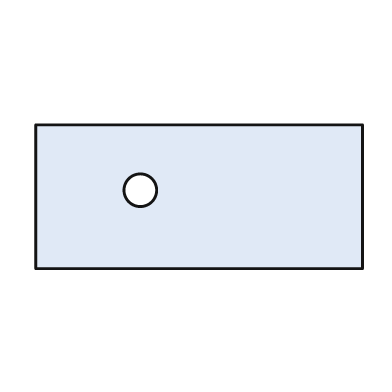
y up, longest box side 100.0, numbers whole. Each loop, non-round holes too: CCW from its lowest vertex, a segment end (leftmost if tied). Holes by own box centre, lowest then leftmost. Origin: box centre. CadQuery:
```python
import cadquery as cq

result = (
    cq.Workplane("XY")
    .moveTo(-50.0, -22.0)
    .lineTo(50.0, -22.0)
    .lineTo(50.0, 22.0)
    .lineTo(-50.0, 22.0)
    .close()
    .moveTo(-18.0, 2.0)
    .circle(5.0)
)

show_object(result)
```